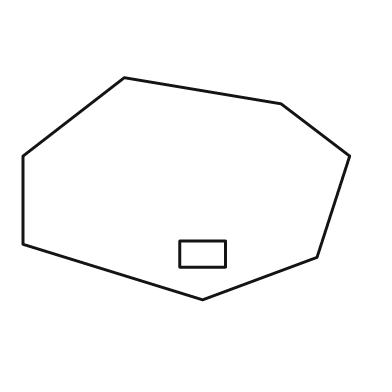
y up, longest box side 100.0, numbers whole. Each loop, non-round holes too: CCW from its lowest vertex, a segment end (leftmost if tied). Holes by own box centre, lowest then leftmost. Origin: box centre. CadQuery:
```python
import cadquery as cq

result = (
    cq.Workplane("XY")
    .moveTo(5.0, -34.0)
    .lineTo(40.0, -21.0)
    .lineTo(50.0, 10.0)
    .lineTo(29.0, 26.0)
    .lineTo(-19.0, 34.0)
    .lineTo(-50.0, 10.0)
    .lineTo(-50.0, -17.0)
    .close()
    .moveTo(-2.0, -24.0)
    .lineTo(12.0, -24.0)
    .lineTo(12.0, -16.0)
    .lineTo(-2.0, -16.0)
    .close()
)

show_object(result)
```